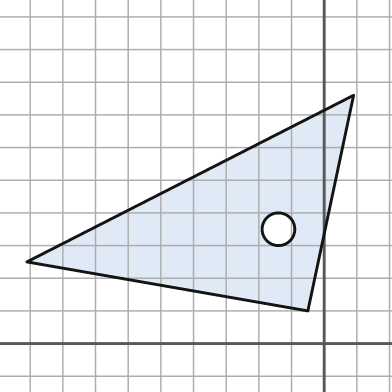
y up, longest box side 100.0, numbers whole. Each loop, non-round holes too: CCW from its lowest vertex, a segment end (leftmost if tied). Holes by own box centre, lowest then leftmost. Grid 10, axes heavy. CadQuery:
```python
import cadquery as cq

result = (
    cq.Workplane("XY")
    .moveTo(-5.0, 10.0)
    .lineTo(9.0, 76.0)
    .lineTo(-91.0, 25.0)
    .close()
    .moveTo(-14.0, 35.0)
    .circle(5.0)
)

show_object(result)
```